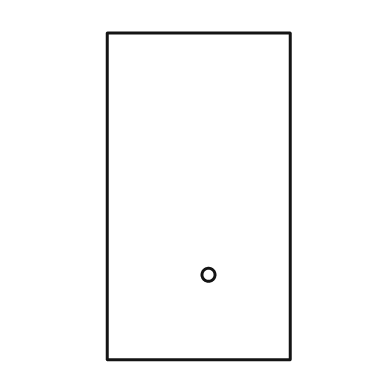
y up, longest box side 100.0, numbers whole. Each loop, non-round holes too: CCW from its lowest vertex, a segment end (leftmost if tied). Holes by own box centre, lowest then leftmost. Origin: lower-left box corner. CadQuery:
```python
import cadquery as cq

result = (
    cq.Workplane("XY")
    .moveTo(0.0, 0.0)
    .lineTo(56.0, 0.0)
    .lineTo(56.0, 100.0)
    .lineTo(0.0, 100.0)
    .close()
    .moveTo(31.0, 26.0)
    .circle(2.0)
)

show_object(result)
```